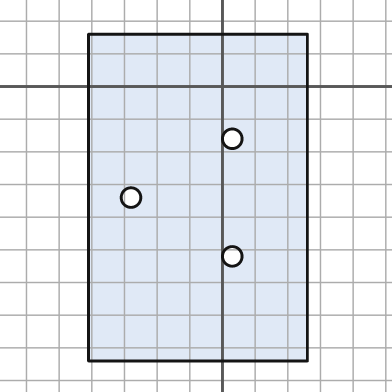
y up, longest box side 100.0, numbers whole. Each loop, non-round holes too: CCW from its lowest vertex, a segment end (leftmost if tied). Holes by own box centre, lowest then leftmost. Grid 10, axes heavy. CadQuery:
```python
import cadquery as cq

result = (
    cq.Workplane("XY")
    .moveTo(-41.0, -84.0)
    .lineTo(26.0, -84.0)
    .lineTo(26.0, 16.0)
    .lineTo(-41.0, 16.0)
    .close()
    .moveTo(3.0, -52.0)
    .circle(3.0)
    .moveTo(-28.0, -34.0)
    .circle(3.0)
    .moveTo(3.0, -16.0)
    .circle(3.0)
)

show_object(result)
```